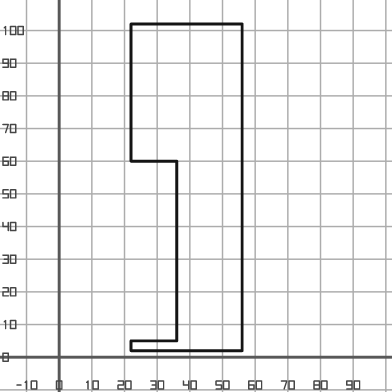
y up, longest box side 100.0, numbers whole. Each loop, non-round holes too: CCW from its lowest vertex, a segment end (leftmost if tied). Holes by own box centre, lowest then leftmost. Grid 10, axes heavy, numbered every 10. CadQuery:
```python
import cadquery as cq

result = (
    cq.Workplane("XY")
    .moveTo(22.0, 2.0)
    .lineTo(56.0, 2.0)
    .lineTo(56.0, 102.0)
    .lineTo(22.0, 102.0)
    .lineTo(22.0, 60.0)
    .lineTo(36.0, 60.0)
    .lineTo(36.0, 5.0)
    .lineTo(22.0, 5.0)
    .close()
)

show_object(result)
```